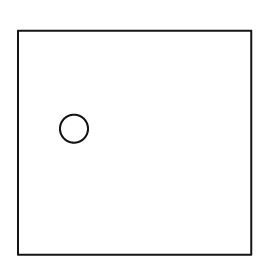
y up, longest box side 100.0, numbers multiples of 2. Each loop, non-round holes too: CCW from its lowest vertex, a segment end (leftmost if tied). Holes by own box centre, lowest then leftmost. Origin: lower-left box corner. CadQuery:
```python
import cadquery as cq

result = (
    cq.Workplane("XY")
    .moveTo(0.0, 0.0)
    .lineTo(100.0, 0.0)
    .lineTo(100.0, 96.0)
    .lineTo(0.0, 96.0)
    .close()
    .moveTo(24.0, 54.0)
    .circle(6.0)
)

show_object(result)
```